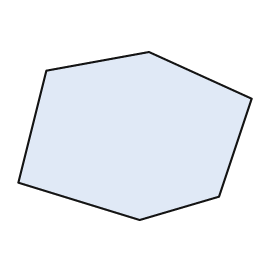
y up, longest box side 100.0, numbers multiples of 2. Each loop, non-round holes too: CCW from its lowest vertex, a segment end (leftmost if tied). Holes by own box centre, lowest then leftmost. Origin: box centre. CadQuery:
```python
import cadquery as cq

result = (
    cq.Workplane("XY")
    .moveTo(2.0, -36.0)
    .lineTo(36.0, -26.0)
    .lineTo(50.0, 16.0)
    .lineTo(6.0, 36.0)
    .lineTo(-38.0, 28.0)
    .lineTo(-50.0, -20.0)
    .close()
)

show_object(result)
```